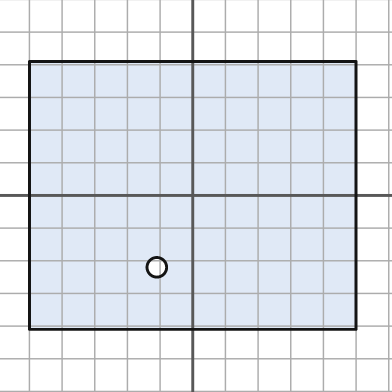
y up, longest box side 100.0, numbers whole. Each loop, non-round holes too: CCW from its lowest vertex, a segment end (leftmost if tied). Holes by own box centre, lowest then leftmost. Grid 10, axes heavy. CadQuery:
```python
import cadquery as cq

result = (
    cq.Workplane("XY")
    .moveTo(-50.0, -41.0)
    .lineTo(50.0, -41.0)
    .lineTo(50.0, 41.0)
    .lineTo(-50.0, 41.0)
    .close()
    .moveTo(-11.0, -22.0)
    .circle(3.0)
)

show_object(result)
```